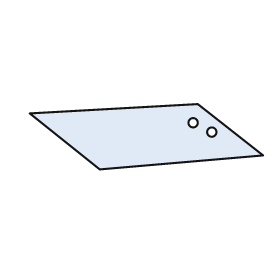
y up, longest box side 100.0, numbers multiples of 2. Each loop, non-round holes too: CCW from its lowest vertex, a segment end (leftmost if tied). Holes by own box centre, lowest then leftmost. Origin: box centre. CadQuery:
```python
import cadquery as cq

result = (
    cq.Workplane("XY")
    .moveTo(-20.0, -14.0)
    .lineTo(50.0, -8.0)
    .lineTo(22.0, 14.0)
    .lineTo(-50.0, 10.0)
    .close()
    .moveTo(28.0, 2.0)
    .circle(2.0)
    .moveTo(20.0, 6.0)
    .circle(2.0)
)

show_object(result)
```